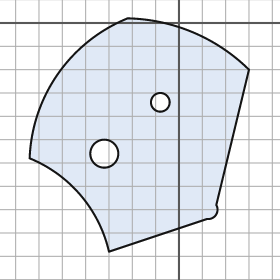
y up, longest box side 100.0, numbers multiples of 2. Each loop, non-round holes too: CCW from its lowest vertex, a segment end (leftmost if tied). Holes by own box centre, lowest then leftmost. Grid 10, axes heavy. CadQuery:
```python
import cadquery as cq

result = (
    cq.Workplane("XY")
    .moveTo(-30.0, -98.0)
    .lineTo(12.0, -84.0)
    .threePointArc((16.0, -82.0), (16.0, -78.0))
    .lineTo(30.0, -20.0)
    .threePointArc((6.0, -4.0), (-22.0, 2.0))
    .threePointArc((-52.0, -22.0), (-64.0, -58.0))
    .threePointArc((-42.0, -74.0), (-30.0, -98.0))
    .close()
    .moveTo(-32.0, -56.0)
    .circle(6.0)
    .moveTo(-8.0, -34.0)
    .circle(4.0)
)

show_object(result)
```